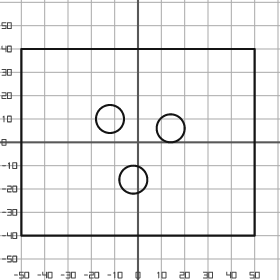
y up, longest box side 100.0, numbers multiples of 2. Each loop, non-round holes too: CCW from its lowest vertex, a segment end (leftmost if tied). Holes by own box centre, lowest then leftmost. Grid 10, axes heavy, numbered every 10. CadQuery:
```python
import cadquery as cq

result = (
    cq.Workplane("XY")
    .moveTo(-50.0, -40.0)
    .lineTo(50.0, -40.0)
    .lineTo(50.0, 40.0)
    .lineTo(-50.0, 40.0)
    .close()
    .moveTo(-2.0, -16.0)
    .circle(6.0)
    .moveTo(14.0, 6.0)
    .circle(6.0)
    .moveTo(-12.0, 10.0)
    .circle(6.0)
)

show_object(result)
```